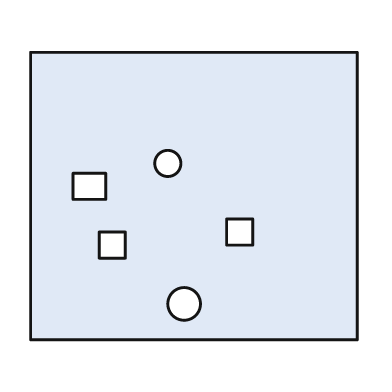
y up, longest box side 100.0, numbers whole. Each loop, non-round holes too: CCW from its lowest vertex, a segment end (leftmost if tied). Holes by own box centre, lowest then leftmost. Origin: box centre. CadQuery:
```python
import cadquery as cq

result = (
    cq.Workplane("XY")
    .moveTo(-50.0, -44.0)
    .lineTo(50.0, -44.0)
    .lineTo(50.0, 44.0)
    .lineTo(-50.0, 44.0)
    .close()
    .moveTo(-3.0, -33.0)
    .circle(5.0)
    .moveTo(-29.0, -19.0)
    .lineTo(-21.0, -19.0)
    .lineTo(-21.0, -11.0)
    .lineTo(-29.0, -11.0)
    .close()
    .moveTo(10.0, -15.0)
    .lineTo(18.0, -15.0)
    .lineTo(18.0, -7.0)
    .lineTo(10.0, -7.0)
    .close()
    .moveTo(-37.0, -1.0)
    .lineTo(-27.0, -1.0)
    .lineTo(-27.0, 7.0)
    .lineTo(-37.0, 7.0)
    .close()
    .moveTo(-8.0, 10.0)
    .circle(4.0)
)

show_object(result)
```